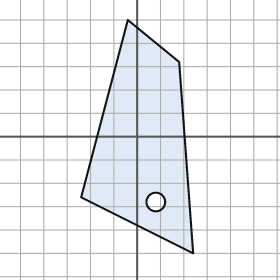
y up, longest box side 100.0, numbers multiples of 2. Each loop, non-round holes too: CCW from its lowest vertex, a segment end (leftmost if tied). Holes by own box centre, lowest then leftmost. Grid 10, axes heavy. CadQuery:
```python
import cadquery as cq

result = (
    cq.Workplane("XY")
    .moveTo(24.0, -50.0)
    .lineTo(18.0, 32.0)
    .lineTo(-4.0, 50.0)
    .lineTo(-24.0, -26.0)
    .close()
    .moveTo(8.0, -28.0)
    .circle(4.0)
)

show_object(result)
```